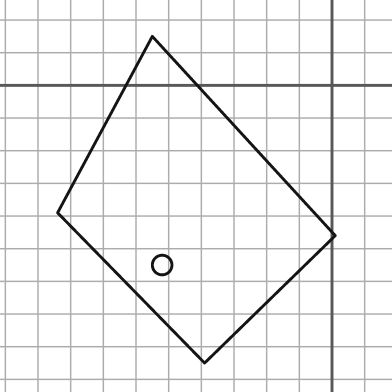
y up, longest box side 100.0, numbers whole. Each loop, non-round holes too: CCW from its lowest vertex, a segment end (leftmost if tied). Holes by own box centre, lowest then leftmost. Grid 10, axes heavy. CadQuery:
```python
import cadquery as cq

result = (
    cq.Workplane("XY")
    .moveTo(-39.0, -85.0)
    .lineTo(1.0, -46.0)
    .lineTo(-55.0, 15.0)
    .lineTo(-84.0, -39.0)
    .close()
    .moveTo(-52.0, -55.0)
    .circle(3.0)
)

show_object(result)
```